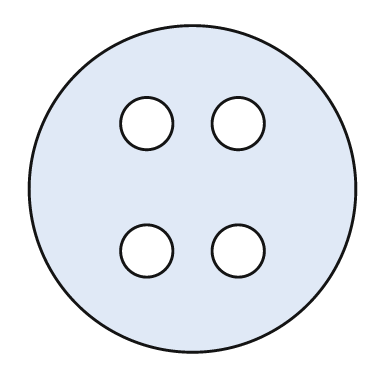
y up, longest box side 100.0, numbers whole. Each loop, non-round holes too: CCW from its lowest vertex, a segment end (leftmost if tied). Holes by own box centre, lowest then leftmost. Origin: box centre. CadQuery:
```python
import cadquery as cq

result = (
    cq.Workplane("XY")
    .moveTo(0.0, 0.0)
    .circle(50.0)
    .moveTo(-14.0, -19.0)
    .circle(8.0)
    .moveTo(14.0, -19.0)
    .circle(8.0)
    .moveTo(-14.0, 20.0)
    .circle(8.0)
    .moveTo(14.0, 20.0)
    .circle(8.0)
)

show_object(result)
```